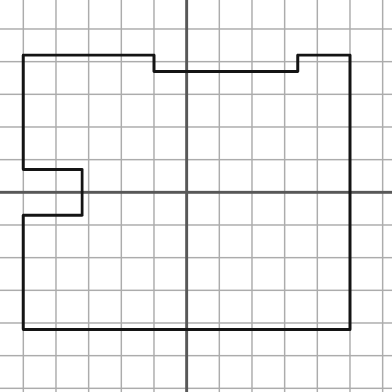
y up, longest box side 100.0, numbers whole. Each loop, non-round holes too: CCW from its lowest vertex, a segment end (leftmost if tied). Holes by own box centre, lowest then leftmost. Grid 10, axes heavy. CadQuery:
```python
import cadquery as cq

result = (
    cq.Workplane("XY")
    .moveTo(-50.0, -42.0)
    .lineTo(50.0, -42.0)
    .lineTo(50.0, 42.0)
    .lineTo(34.0, 42.0)
    .lineTo(34.0, 37.0)
    .lineTo(-10.0, 37.0)
    .lineTo(-10.0, 42.0)
    .lineTo(-50.0, 42.0)
    .lineTo(-50.0, 7.0)
    .lineTo(-32.0, 7.0)
    .lineTo(-32.0, -7.0)
    .lineTo(-50.0, -7.0)
    .close()
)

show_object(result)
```